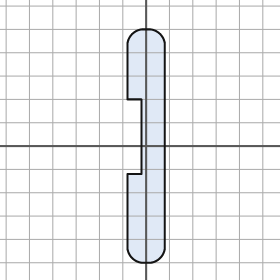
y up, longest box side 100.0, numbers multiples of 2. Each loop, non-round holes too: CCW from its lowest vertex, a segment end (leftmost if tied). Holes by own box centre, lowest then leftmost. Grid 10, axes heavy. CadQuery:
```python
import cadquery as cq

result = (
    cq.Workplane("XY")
    .moveTo(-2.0, -50.0)
    .lineTo(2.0, -50.0)
    .threePointArc((6.0, -48.0), (8.0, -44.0))
    .lineTo(8.0, 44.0)
    .threePointArc((6.0, 48.0), (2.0, 50.0))
    .lineTo(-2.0, 50.0)
    .threePointArc((-6.0, 48.0), (-8.0, 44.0))
    .lineTo(-8.0, 20.0)
    .lineTo(-2.0, 20.0)
    .lineTo(-2.0, -12.0)
    .lineTo(-8.0, -12.0)
    .lineTo(-8.0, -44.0)
    .threePointArc((-6.0, -48.0), (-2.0, -50.0))
    .close()
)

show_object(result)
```